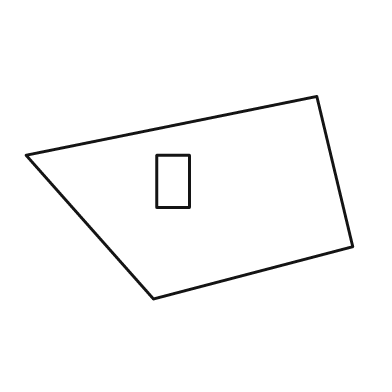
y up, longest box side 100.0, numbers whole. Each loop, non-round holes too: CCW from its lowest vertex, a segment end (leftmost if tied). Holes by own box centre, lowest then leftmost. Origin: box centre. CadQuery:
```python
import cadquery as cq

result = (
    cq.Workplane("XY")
    .moveTo(-11.0, -31.0)
    .lineTo(50.0, -15.0)
    .lineTo(39.0, 31.0)
    .lineTo(-50.0, 13.0)
    .close()
    .moveTo(-10.0, -3.0)
    .lineTo(0.0, -3.0)
    .lineTo(0.0, 13.0)
    .lineTo(-10.0, 13.0)
    .close()
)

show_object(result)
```